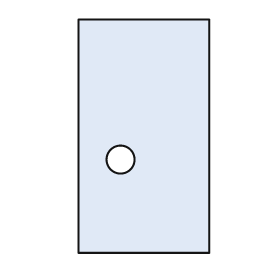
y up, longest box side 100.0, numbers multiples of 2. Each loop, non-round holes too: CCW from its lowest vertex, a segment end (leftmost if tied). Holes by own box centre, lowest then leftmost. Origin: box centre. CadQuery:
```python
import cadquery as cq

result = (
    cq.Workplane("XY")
    .moveTo(-28.0, -50.0)
    .lineTo(28.0, -50.0)
    .lineTo(28.0, 50.0)
    .lineTo(-28.0, 50.0)
    .close()
    .moveTo(-10.0, -10.0)
    .circle(6.0)
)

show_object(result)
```